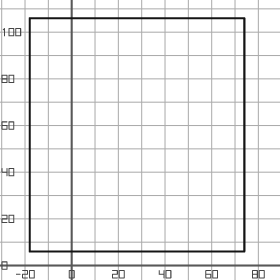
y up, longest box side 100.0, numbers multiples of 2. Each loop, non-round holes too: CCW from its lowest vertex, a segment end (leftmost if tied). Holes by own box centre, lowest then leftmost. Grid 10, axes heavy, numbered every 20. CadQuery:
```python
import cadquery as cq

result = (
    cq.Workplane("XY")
    .moveTo(-18.0, 6.0)
    .lineTo(74.0, 6.0)
    .lineTo(74.0, 106.0)
    .lineTo(-18.0, 106.0)
    .close()
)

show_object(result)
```